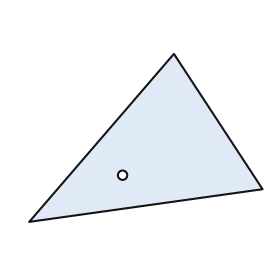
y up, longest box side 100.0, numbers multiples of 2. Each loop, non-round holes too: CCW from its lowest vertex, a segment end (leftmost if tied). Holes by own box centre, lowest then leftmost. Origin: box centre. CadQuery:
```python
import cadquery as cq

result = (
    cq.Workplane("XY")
    .moveTo(-50.0, -36.0)
    .lineTo(50.0, -22.0)
    .lineTo(12.0, 36.0)
    .close()
    .moveTo(-10.0, -16.0)
    .circle(2.0)
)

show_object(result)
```